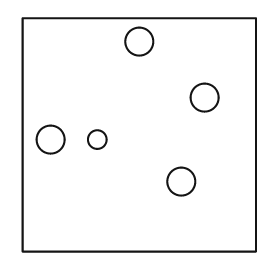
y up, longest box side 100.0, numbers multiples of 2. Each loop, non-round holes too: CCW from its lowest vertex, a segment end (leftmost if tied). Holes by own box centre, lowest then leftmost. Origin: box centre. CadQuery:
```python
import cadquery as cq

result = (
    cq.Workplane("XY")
    .moveTo(-50.0, -50.0)
    .lineTo(50.0, -50.0)
    .lineTo(50.0, 50.0)
    .lineTo(-50.0, 50.0)
    .close()
    .moveTo(18.0, -20.0)
    .circle(6.0)
    .moveTo(-38.0, -2.0)
    .circle(6.0)
    .moveTo(-18.0, -2.0)
    .circle(4.0)
    .moveTo(28.0, 16.0)
    .circle(6.0)
    .moveTo(0.0, 40.0)
    .circle(6.0)
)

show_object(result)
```